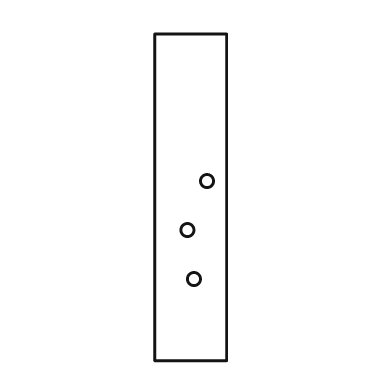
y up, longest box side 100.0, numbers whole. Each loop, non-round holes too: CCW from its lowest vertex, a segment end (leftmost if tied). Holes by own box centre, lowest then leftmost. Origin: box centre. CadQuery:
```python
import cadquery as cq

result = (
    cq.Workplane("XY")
    .moveTo(-11.0, -50.0)
    .lineTo(11.0, -50.0)
    .lineTo(11.0, 50.0)
    .lineTo(-11.0, 50.0)
    .close()
    .moveTo(1.0, -25.0)
    .circle(2.0)
    .moveTo(-1.0, -10.0)
    .circle(2.0)
    .moveTo(5.0, 5.0)
    .circle(2.0)
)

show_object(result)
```